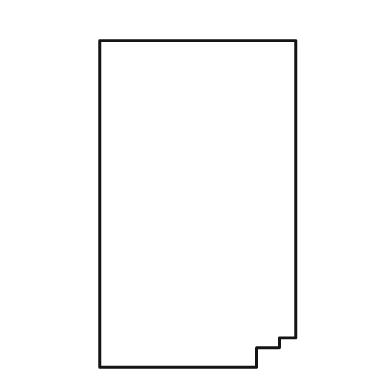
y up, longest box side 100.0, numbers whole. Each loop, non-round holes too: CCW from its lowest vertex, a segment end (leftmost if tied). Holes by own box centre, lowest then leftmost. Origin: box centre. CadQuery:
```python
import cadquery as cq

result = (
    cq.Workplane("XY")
    .moveTo(-30.0, -50.0)
    .lineTo(18.0, -50.0)
    .lineTo(18.0, -44.0)
    .lineTo(25.0, -44.0)
    .lineTo(25.0, -41.0)
    .lineTo(30.0, -41.0)
    .lineTo(30.0, 50.0)
    .lineTo(-30.0, 50.0)
    .close()
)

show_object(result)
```